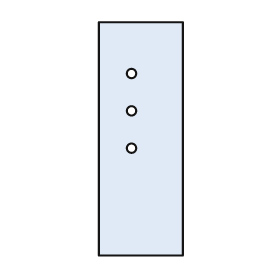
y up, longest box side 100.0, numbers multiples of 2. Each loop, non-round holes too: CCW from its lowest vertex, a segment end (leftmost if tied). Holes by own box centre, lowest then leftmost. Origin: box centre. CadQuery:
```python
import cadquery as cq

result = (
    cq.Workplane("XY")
    .moveTo(-18.0, -50.0)
    .lineTo(18.0, -50.0)
    .lineTo(18.0, 50.0)
    .lineTo(-18.0, 50.0)
    .close()
    .moveTo(-4.0, -4.0)
    .circle(2.0)
    .moveTo(-4.0, 12.0)
    .circle(2.0)
    .moveTo(-4.0, 28.0)
    .circle(2.0)
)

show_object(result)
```